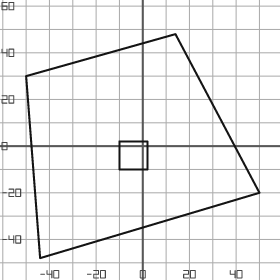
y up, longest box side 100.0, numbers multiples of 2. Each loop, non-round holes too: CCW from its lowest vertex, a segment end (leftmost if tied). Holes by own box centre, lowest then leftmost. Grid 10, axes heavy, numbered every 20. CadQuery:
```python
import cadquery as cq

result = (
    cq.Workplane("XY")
    .moveTo(-44.0, -48.0)
    .lineTo(50.0, -20.0)
    .lineTo(14.0, 48.0)
    .lineTo(-50.0, 30.0)
    .close()
    .moveTo(-10.0, -10.0)
    .lineTo(2.0, -10.0)
    .lineTo(2.0, 2.0)
    .lineTo(-10.0, 2.0)
    .close()
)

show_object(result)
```